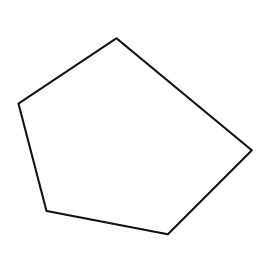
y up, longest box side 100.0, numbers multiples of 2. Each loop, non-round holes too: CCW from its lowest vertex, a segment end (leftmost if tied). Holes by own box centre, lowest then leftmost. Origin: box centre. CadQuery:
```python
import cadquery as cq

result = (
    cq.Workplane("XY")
    .moveTo(14.0, -42.0)
    .lineTo(50.0, -6.0)
    .lineTo(-8.0, 42.0)
    .lineTo(-50.0, 14.0)
    .lineTo(-38.0, -32.0)
    .close()
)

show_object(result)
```